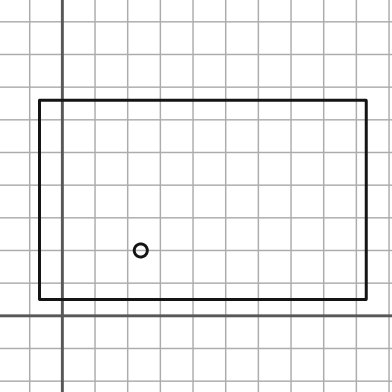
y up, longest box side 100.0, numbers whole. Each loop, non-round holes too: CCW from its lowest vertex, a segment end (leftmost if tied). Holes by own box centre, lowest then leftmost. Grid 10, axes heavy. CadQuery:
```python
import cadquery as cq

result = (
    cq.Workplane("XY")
    .moveTo(-7.0, 5.0)
    .lineTo(93.0, 5.0)
    .lineTo(93.0, 66.0)
    .lineTo(-7.0, 66.0)
    .close()
    .moveTo(24.0, 20.0)
    .circle(2.0)
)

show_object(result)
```